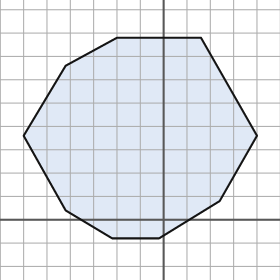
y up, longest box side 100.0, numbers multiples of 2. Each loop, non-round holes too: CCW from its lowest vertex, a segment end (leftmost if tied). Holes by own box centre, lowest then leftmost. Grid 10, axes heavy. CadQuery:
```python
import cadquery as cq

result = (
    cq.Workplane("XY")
    .moveTo(-22.0, -8.0)
    .lineTo(-2.0, -8.0)
    .lineTo(24.0, 8.0)
    .lineTo(40.0, 36.0)
    .lineTo(16.0, 78.0)
    .lineTo(-20.0, 78.0)
    .lineTo(-42.0, 66.0)
    .lineTo(-60.0, 36.0)
    .lineTo(-42.0, 4.0)
    .close()
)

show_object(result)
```